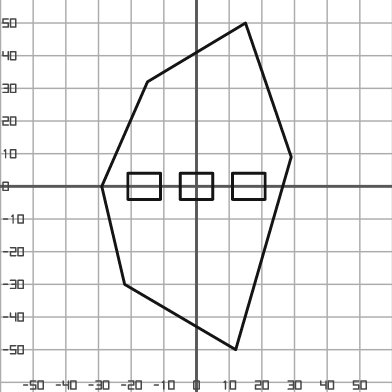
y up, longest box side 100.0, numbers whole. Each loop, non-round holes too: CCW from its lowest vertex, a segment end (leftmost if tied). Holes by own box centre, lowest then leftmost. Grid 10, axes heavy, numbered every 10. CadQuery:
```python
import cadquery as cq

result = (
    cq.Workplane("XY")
    .moveTo(12.0, -50.0)
    .lineTo(29.0, 9.0)
    .lineTo(15.0, 50.0)
    .lineTo(-15.0, 32.0)
    .lineTo(-29.0, 0.0)
    .lineTo(-22.0, -30.0)
    .close()
    .moveTo(-21.0, -4.0)
    .lineTo(-11.0, -4.0)
    .lineTo(-11.0, 4.0)
    .lineTo(-21.0, 4.0)
    .close()
    .moveTo(-5.0, -4.0)
    .lineTo(5.0, -4.0)
    .lineTo(5.0, 4.0)
    .lineTo(-5.0, 4.0)
    .close()
    .moveTo(11.0, -4.0)
    .lineTo(21.0, -4.0)
    .lineTo(21.0, 4.0)
    .lineTo(11.0, 4.0)
    .close()
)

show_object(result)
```